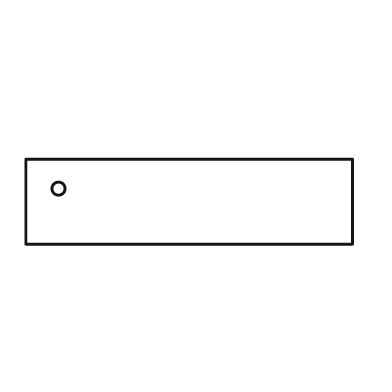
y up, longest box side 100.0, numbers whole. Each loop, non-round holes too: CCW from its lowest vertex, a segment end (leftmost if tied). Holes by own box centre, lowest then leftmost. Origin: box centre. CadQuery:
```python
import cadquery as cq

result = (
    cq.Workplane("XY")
    .moveTo(-50.0, -13.0)
    .lineTo(50.0, -13.0)
    .lineTo(50.0, 13.0)
    .lineTo(-50.0, 13.0)
    .close()
    .moveTo(-40.0, 4.0)
    .circle(2.0)
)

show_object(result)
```